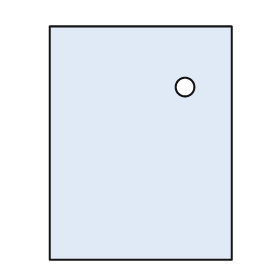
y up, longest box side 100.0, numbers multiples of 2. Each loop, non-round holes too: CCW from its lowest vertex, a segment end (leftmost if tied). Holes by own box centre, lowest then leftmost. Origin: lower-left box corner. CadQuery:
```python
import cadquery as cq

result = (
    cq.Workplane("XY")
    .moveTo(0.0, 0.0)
    .lineTo(78.0, 0.0)
    .lineTo(78.0, 100.0)
    .lineTo(0.0, 100.0)
    .close()
    .moveTo(58.0, 74.0)
    .circle(4.0)
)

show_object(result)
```